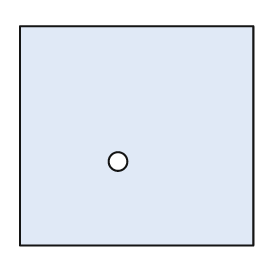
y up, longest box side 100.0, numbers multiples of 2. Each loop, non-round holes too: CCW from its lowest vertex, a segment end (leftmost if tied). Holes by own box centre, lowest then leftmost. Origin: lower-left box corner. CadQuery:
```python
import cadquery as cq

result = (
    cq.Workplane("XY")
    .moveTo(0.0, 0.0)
    .lineTo(100.0, 0.0)
    .lineTo(100.0, 94.0)
    .lineTo(0.0, 94.0)
    .close()
    .moveTo(42.0, 36.0)
    .circle(4.0)
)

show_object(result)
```